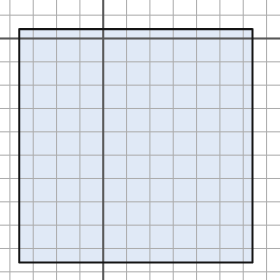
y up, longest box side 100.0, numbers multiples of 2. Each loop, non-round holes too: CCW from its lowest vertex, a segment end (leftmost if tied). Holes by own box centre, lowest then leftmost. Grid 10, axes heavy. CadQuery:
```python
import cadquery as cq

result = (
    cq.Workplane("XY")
    .moveTo(-36.0, -96.0)
    .lineTo(64.0, -96.0)
    .lineTo(64.0, 4.0)
    .lineTo(-36.0, 4.0)
    .close()
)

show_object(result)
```